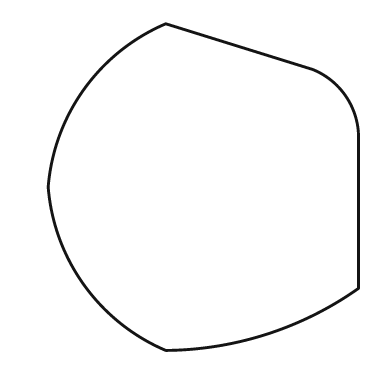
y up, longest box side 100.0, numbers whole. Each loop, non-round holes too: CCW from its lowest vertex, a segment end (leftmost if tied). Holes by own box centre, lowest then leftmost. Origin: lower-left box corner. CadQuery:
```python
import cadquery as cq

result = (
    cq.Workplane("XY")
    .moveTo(36.0, 0.0)
    .threePointArc((67.0, 5.0), (95.0, 19.0))
    .lineTo(95.0, 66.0)
    .threePointArc((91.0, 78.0), (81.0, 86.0))
    .lineTo(36.0, 100.0)
    .threePointArc((11.0, 80.0), (0.0, 50.0))
    .threePointArc((11.0, 20.0), (36.0, 0.0))
    .close()
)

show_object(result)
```